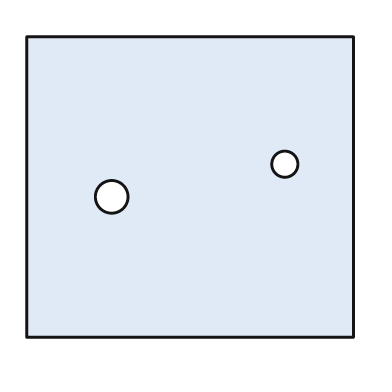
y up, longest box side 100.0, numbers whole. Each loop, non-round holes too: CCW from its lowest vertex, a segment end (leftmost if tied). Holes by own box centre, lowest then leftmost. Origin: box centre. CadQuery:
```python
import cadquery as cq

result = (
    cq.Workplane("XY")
    .moveTo(-50.0, -46.0)
    .lineTo(50.0, -46.0)
    .lineTo(50.0, 46.0)
    .lineTo(-50.0, 46.0)
    .close()
    .moveTo(-24.0, -3.0)
    .circle(5.0)
    .moveTo(29.0, 7.0)
    .circle(4.0)
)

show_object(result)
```